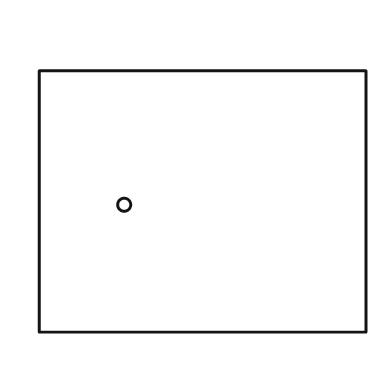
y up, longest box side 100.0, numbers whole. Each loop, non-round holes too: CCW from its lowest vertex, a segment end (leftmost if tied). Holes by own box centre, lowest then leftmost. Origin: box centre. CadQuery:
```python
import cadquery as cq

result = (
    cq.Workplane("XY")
    .moveTo(-50.0, -40.0)
    .lineTo(50.0, -40.0)
    .lineTo(50.0, 40.0)
    .lineTo(-50.0, 40.0)
    .close()
    .moveTo(-24.0, -1.0)
    .circle(2.0)
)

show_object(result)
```